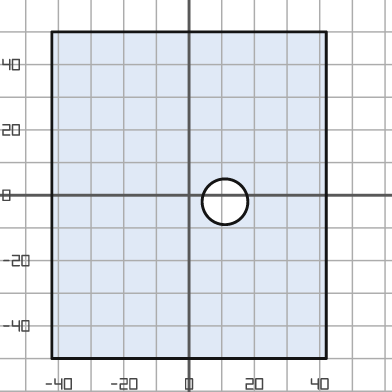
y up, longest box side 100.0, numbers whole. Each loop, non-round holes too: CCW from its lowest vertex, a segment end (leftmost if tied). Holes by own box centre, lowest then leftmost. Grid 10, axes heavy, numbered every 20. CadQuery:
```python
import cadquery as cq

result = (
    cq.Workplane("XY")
    .moveTo(-42.0, -50.0)
    .lineTo(42.0, -50.0)
    .lineTo(42.0, 50.0)
    .lineTo(-42.0, 50.0)
    .close()
    .moveTo(11.0, -2.0)
    .circle(7.0)
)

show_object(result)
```